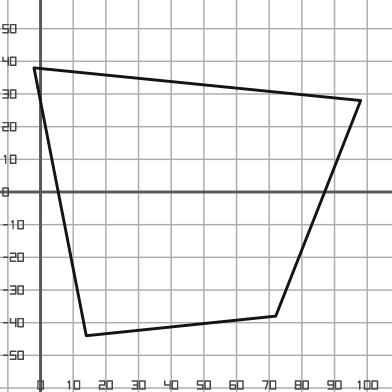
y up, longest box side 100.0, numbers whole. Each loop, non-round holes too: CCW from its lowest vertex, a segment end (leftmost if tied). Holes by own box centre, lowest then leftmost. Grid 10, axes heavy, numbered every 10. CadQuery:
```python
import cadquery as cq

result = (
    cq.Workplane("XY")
    .moveTo(14.0, -44.0)
    .lineTo(72.0, -38.0)
    .lineTo(98.0, 28.0)
    .lineTo(-2.0, 38.0)
    .close()
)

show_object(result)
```